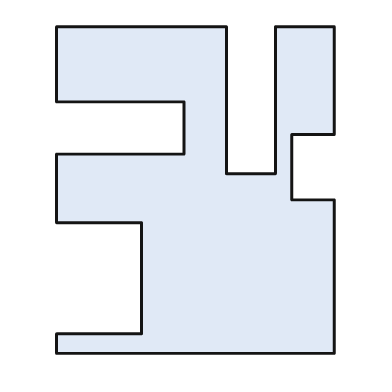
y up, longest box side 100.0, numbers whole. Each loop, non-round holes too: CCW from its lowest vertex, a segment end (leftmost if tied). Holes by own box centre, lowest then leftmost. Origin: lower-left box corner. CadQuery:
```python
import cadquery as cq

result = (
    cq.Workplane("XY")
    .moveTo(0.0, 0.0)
    .lineTo(85.0, 0.0)
    .lineTo(85.0, 47.0)
    .lineTo(72.0, 47.0)
    .lineTo(72.0, 67.0)
    .lineTo(85.0, 67.0)
    .lineTo(85.0, 100.0)
    .lineTo(67.0, 100.0)
    .lineTo(67.0, 55.0)
    .lineTo(52.0, 55.0)
    .lineTo(52.0, 100.0)
    .lineTo(0.0, 100.0)
    .lineTo(0.0, 77.0)
    .lineTo(39.0, 77.0)
    .lineTo(39.0, 61.0)
    .lineTo(0.0, 61.0)
    .lineTo(0.0, 40.0)
    .lineTo(26.0, 40.0)
    .lineTo(26.0, 6.0)
    .lineTo(0.0, 6.0)
    .close()
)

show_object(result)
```